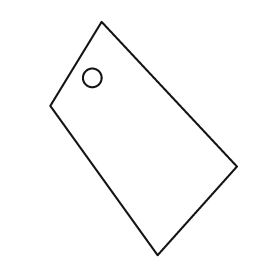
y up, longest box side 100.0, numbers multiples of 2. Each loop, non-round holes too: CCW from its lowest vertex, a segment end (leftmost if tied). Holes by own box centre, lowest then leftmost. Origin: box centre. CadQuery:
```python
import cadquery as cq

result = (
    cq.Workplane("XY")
    .moveTo(6.0, -50.0)
    .lineTo(40.0, -12.0)
    .lineTo(-18.0, 50.0)
    .lineTo(-40.0, 14.0)
    .close()
    .moveTo(-22.0, 26.0)
    .circle(4.0)
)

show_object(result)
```